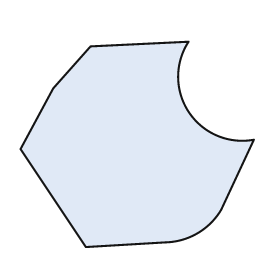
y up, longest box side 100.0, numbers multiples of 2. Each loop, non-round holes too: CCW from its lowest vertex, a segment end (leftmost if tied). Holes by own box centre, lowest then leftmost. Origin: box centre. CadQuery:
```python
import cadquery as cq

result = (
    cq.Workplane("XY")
    .moveTo(-22.0, -44.0)
    .lineTo(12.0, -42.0)
    .threePointArc((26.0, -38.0), (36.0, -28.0))
    .lineTo(50.0, 2.0)
    .threePointArc((22.0, 14.0), (22.0, 44.0))
    .lineTo(-20.0, 42.0)
    .lineTo(-36.0, 24.0)
    .lineTo(-50.0, -2.0)
    .close()
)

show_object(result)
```